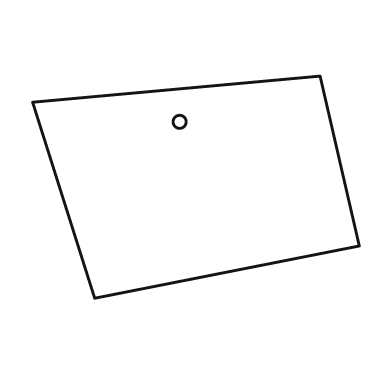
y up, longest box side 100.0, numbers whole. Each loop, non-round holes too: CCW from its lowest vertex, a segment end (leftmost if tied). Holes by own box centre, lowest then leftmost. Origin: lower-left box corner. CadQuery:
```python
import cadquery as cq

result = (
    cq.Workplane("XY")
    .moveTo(19.0, 0.0)
    .lineTo(100.0, 16.0)
    .lineTo(88.0, 68.0)
    .lineTo(0.0, 60.0)
    .close()
    .moveTo(45.0, 54.0)
    .circle(2.0)
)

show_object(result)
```